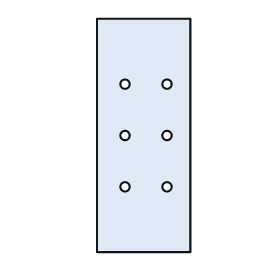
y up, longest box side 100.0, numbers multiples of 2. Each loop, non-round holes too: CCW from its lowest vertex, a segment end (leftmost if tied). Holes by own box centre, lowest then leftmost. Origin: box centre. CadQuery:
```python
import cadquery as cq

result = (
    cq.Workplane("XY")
    .moveTo(-20.0, -50.0)
    .lineTo(20.0, -50.0)
    .lineTo(20.0, 50.0)
    .lineTo(-20.0, 50.0)
    .close()
    .moveTo(-8.0, -22.0)
    .circle(2.0)
    .moveTo(10.0, -22.0)
    .circle(2.0)
    .moveTo(-8.0, 0.0)
    .circle(2.0)
    .moveTo(10.0, 0.0)
    .circle(2.0)
    .moveTo(-8.0, 22.0)
    .circle(2.0)
    .moveTo(10.0, 22.0)
    .circle(2.0)
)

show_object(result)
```